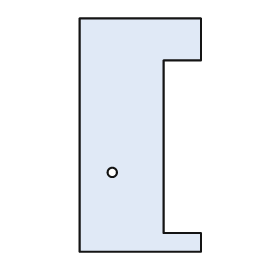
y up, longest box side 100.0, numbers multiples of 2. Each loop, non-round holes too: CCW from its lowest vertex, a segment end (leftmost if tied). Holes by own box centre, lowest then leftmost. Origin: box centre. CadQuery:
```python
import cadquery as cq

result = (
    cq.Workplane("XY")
    .moveTo(-26.0, -50.0)
    .lineTo(26.0, -50.0)
    .lineTo(26.0, -42.0)
    .lineTo(10.0, -42.0)
    .lineTo(10.0, 32.0)
    .lineTo(26.0, 32.0)
    .lineTo(26.0, 50.0)
    .lineTo(-26.0, 50.0)
    .close()
    .moveTo(-12.0, -16.0)
    .circle(2.0)
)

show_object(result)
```